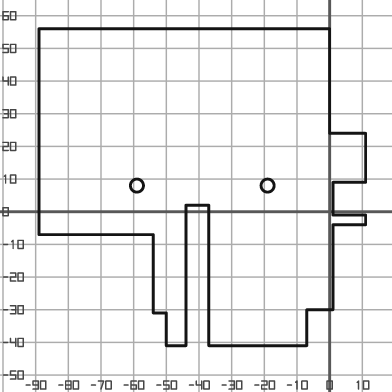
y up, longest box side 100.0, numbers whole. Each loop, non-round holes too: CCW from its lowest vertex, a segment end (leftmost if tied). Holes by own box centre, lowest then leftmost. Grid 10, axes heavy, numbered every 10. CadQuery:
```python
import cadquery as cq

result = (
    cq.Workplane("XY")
    .moveTo(-50.0, -41.0)
    .lineTo(-44.0, -41.0)
    .lineTo(-44.0, 2.0)
    .lineTo(-37.0, 2.0)
    .lineTo(-37.0, -41.0)
    .lineTo(-7.0, -41.0)
    .lineTo(-7.0, -30.0)
    .lineTo(1.0, -30.0)
    .lineTo(1.0, -4.0)
    .lineTo(11.0, -4.0)
    .lineTo(11.0, -1.0)
    .lineTo(1.0, -1.0)
    .lineTo(1.0, 9.0)
    .lineTo(11.0, 9.0)
    .lineTo(11.0, 24.0)
    .lineTo(0.0, 24.0)
    .lineTo(0.0, 56.0)
    .lineTo(-89.0, 56.0)
    .lineTo(-89.0, -7.0)
    .lineTo(-54.0, -7.0)
    .lineTo(-54.0, -31.0)
    .lineTo(-50.0, -31.0)
    .close()
    .moveTo(-59.0, 8.0)
    .circle(2.0)
    .moveTo(-19.0, 8.0)
    .circle(2.0)
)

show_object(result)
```